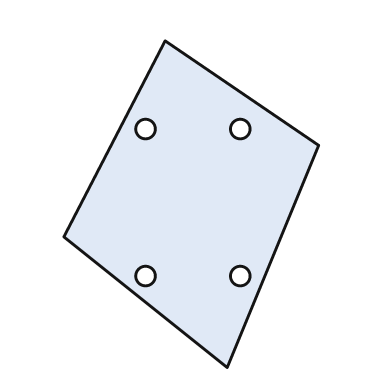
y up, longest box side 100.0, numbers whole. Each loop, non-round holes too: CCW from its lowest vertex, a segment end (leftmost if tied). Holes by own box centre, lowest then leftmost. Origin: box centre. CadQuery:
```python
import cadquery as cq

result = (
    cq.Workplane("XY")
    .moveTo(11.0, -50.0)
    .lineTo(39.0, 18.0)
    .lineTo(-8.0, 50.0)
    .lineTo(-39.0, -10.0)
    .close()
    .moveTo(-14.0, -22.0)
    .circle(3.0)
    .moveTo(15.0, -22.0)
    .circle(3.0)
    .moveTo(-14.0, 23.0)
    .circle(3.0)
    .moveTo(15.0, 23.0)
    .circle(3.0)
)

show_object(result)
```